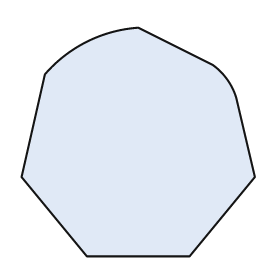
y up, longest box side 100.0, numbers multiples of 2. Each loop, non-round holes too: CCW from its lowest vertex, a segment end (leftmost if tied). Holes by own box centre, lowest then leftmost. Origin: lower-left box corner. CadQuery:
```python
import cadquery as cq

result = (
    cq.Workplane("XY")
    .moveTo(28.0, 0.0)
    .lineTo(72.0, 0.0)
    .lineTo(100.0, 34.0)
    .lineTo(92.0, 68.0)
    .threePointArc((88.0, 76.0), (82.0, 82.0))
    .lineTo(50.0, 98.0)
    .threePointArc((28.0, 92.0), (10.0, 78.0))
    .lineTo(0.0, 34.0)
    .close()
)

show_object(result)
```